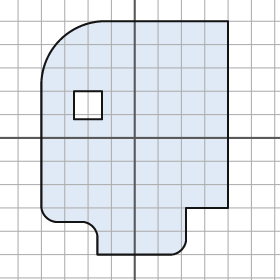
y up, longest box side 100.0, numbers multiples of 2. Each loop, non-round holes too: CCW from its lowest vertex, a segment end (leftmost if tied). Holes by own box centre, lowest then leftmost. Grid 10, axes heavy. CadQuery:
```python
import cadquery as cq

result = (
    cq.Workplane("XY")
    .moveTo(-16.0, -50.0)
    .lineTo(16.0, -50.0)
    .threePointArc((20.0, -48.0), (22.0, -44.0))
    .lineTo(22.0, -30.0)
    .lineTo(40.0, -30.0)
    .lineTo(40.0, 50.0)
    .lineTo(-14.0, 50.0)
    .threePointArc((-32.0, 42.0), (-40.0, 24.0))
    .lineTo(-40.0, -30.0)
    .threePointArc((-38.0, -34.0), (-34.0, -36.0))
    .lineTo(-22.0, -36.0)
    .threePointArc((-18.0, -38.0), (-16.0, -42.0))
    .close()
    .moveTo(-26.0, 8.0)
    .lineTo(-14.0, 8.0)
    .lineTo(-14.0, 20.0)
    .lineTo(-26.0, 20.0)
    .close()
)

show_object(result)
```